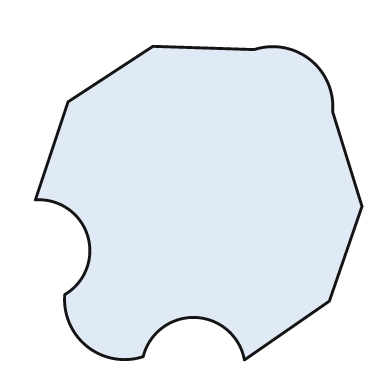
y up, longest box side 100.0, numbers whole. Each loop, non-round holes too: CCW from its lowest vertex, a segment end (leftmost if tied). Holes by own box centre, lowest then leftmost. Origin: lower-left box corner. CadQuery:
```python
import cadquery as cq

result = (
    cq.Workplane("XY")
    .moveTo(64.0, 0.0)
    .lineTo(90.0, 18.0)
    .lineTo(100.0, 47.0)
    .lineTo(91.0, 76.0)
    .threePointArc((84.0, 92.0), (67.0, 95.0))
    .lineTo(36.0, 96.0)
    .lineTo(10.0, 79.0)
    .lineTo(0.0, 49.0)
    .threePointArc((16.0, 38.0), (9.0, 20.0))
    .threePointArc((16.0, 4.0), (33.0, 1.0))
    .threePointArc((49.0, 13.0), (64.0, 0.0))
    .close()
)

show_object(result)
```